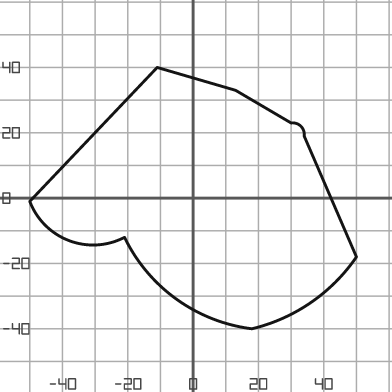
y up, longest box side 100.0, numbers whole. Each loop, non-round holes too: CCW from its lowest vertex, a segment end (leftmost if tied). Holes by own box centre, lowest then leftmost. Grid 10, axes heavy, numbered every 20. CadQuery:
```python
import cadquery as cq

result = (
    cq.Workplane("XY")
    .moveTo(18.0, -40.0)
    .threePointArc((36.0, -32.0), (50.0, -18.0))
    .lineTo(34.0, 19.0)
    .threePointArc((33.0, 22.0), (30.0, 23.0))
    .lineTo(13.0, 33.0)
    .lineTo(-11.0, 40.0)
    .lineTo(-50.0, -1.0)
    .threePointArc((-38.0, -13.0), (-21.0, -12.0))
    .threePointArc((-5.0, -31.0), (18.0, -40.0))
    .close()
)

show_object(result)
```